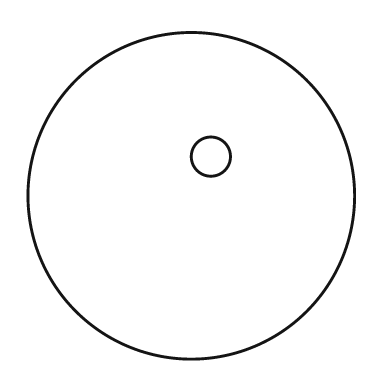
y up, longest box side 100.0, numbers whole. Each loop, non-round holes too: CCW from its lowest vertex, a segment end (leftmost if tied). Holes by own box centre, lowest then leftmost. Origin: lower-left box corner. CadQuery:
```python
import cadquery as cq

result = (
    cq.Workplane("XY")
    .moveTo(50.0, 50.0)
    .circle(50.0)
    .moveTo(56.0, 62.0)
    .circle(6.0)
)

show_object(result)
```